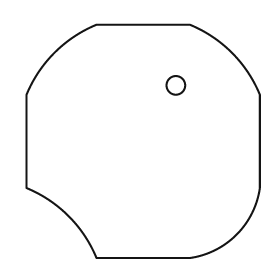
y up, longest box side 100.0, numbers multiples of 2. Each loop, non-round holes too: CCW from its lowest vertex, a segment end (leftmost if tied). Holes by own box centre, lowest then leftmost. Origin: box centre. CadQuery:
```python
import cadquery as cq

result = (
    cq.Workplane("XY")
    .moveTo(-20.0, -50.0)
    .lineTo(20.0, -50.0)
    .threePointArc((40.0, -40.0), (50.0, -20.0))
    .lineTo(50.0, 20.0)
    .threePointArc((38.0, 38.0), (20.0, 50.0))
    .lineTo(-20.0, 50.0)
    .threePointArc((-38.0, 38.0), (-50.0, 20.0))
    .lineTo(-50.0, -20.0)
    .threePointArc((-32.0, -32.0), (-20.0, -50.0))
    .close()
    .moveTo(14.0, 24.0)
    .circle(4.0)
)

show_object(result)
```